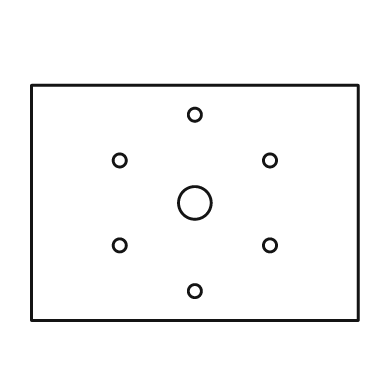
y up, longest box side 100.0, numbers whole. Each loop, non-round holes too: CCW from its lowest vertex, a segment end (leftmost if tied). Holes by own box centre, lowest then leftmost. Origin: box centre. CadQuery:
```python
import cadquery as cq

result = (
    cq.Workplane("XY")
    .moveTo(-50.0, -36.0)
    .lineTo(50.0, -36.0)
    .lineTo(50.0, 36.0)
    .lineTo(-50.0, 36.0)
    .close()
    .moveTo(0.0, -27.0)
    .circle(2.0)
    .moveTo(-23.0, -13.0)
    .circle(2.0)
    .moveTo(23.0, -13.0)
    .circle(2.0)
    .moveTo(0.0, 0.0)
    .circle(5.0)
    .moveTo(-23.0, 13.0)
    .circle(2.0)
    .moveTo(23.0, 13.0)
    .circle(2.0)
    .moveTo(0.0, 27.0)
    .circle(2.0)
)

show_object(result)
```